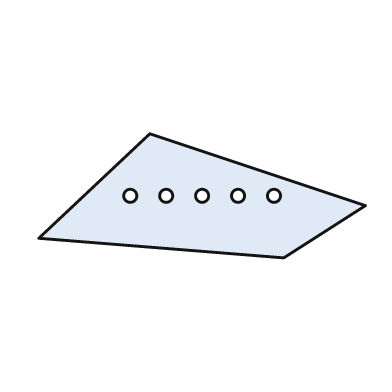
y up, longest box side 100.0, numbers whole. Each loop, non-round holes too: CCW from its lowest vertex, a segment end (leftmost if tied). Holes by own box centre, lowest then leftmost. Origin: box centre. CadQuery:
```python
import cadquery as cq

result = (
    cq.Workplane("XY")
    .moveTo(25.0, -19.0)
    .lineTo(50.0, -3.0)
    .lineTo(-16.0, 19.0)
    .lineTo(-50.0, -13.0)
    .close()
    .moveTo(-22.0, 0.0)
    .circle(2.0)
    .moveTo(-11.0, 0.0)
    .circle(2.0)
    .moveTo(0.0, 0.0)
    .circle(2.0)
    .moveTo(11.0, 0.0)
    .circle(2.0)
    .moveTo(22.0, 0.0)
    .circle(2.0)
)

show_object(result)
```